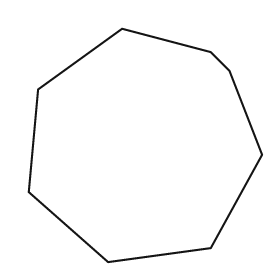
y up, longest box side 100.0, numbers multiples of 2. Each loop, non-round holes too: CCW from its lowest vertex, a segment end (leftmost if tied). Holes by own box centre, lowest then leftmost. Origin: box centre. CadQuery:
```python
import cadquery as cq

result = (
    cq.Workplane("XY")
    .moveTo(-16.0, -50.0)
    .lineTo(28.0, -44.0)
    .lineTo(50.0, -4.0)
    .lineTo(36.0, 32.0)
    .lineTo(28.0, 40.0)
    .lineTo(-10.0, 50.0)
    .lineTo(-46.0, 24.0)
    .lineTo(-50.0, -20.0)
    .close()
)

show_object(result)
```